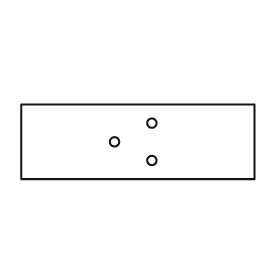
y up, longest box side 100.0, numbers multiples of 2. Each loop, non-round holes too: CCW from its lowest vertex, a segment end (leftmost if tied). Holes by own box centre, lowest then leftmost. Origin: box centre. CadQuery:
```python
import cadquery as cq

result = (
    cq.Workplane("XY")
    .moveTo(-50.0, -16.0)
    .lineTo(50.0, -16.0)
    .lineTo(50.0, 16.0)
    .lineTo(-50.0, 16.0)
    .close()
    .moveTo(6.0, -8.0)
    .circle(2.0)
    .moveTo(-10.0, 0.0)
    .circle(2.0)
    .moveTo(6.0, 8.0)
    .circle(2.0)
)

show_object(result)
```